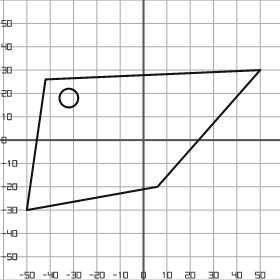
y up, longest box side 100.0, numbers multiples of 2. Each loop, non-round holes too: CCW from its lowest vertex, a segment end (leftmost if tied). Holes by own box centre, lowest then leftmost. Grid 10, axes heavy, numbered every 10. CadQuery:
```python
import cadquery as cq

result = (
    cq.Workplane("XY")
    .moveTo(-50.0, -30.0)
    .lineTo(6.0, -20.0)
    .lineTo(50.0, 30.0)
    .lineTo(-42.0, 26.0)
    .close()
    .moveTo(-32.0, 18.0)
    .circle(4.0)
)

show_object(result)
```